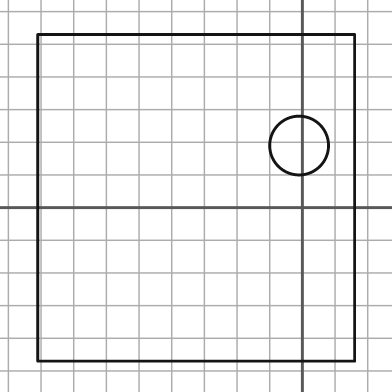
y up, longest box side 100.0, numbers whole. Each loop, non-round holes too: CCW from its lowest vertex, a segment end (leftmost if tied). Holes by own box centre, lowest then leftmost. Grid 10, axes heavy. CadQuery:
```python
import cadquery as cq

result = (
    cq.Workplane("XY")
    .moveTo(-81.0, -47.0)
    .lineTo(16.0, -47.0)
    .lineTo(16.0, 53.0)
    .lineTo(-81.0, 53.0)
    .close()
    .moveTo(-1.0, 19.0)
    .circle(9.0)
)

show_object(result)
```